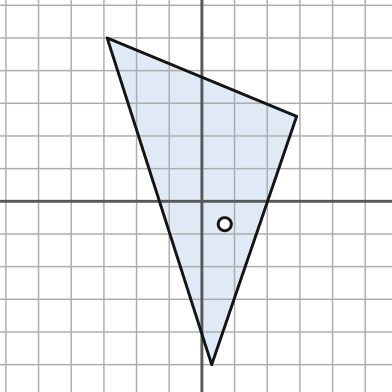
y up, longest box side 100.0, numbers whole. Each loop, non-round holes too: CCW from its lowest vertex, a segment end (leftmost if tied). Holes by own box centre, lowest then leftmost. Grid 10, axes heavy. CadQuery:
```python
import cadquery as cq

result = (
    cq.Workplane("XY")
    .moveTo(3.0, -50.0)
    .lineTo(29.0, 26.0)
    .lineTo(-29.0, 50.0)
    .close()
    .moveTo(7.0, -7.0)
    .circle(2.0)
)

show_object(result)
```